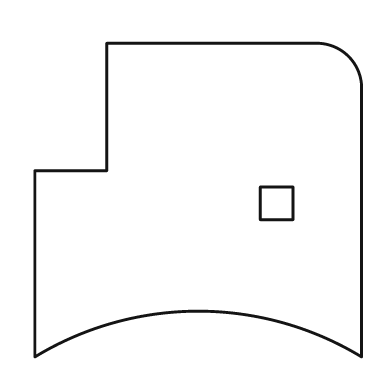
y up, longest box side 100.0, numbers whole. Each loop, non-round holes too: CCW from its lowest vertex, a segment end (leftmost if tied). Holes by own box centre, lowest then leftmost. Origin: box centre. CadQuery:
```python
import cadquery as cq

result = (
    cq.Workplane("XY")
    .moveTo(-50.0, -48.0)
    .threePointArc((0.0, -34.0), (50.0, -48.0))
    .lineTo(50.0, 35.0)
    .threePointArc((46.0, 44.0), (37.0, 48.0))
    .lineTo(-28.0, 48.0)
    .lineTo(-28.0, 9.0)
    .lineTo(-50.0, 9.0)
    .close()
    .moveTo(19.0, -6.0)
    .lineTo(29.0, -6.0)
    .lineTo(29.0, 4.0)
    .lineTo(19.0, 4.0)
    .close()
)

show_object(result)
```